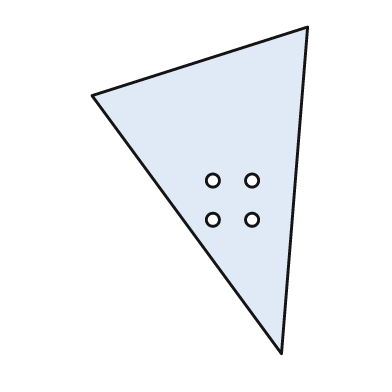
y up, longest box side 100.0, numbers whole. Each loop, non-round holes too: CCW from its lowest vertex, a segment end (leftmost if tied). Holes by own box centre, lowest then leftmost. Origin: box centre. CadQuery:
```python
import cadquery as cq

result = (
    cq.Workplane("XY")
    .moveTo(25.0, -50.0)
    .lineTo(33.0, 50.0)
    .lineTo(-33.0, 29.0)
    .close()
    .moveTo(4.0, -9.0)
    .circle(2.0)
    .moveTo(16.0, -9.0)
    .circle(2.0)
    .moveTo(4.0, 3.0)
    .circle(2.0)
    .moveTo(16.0, 3.0)
    .circle(2.0)
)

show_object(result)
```